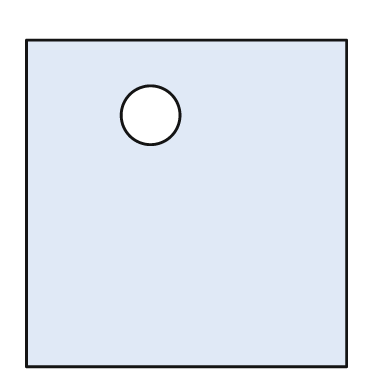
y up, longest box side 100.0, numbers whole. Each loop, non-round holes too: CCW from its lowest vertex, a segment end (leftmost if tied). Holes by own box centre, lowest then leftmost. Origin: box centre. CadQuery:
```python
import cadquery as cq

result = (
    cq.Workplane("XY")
    .moveTo(-49.0, -50.0)
    .lineTo(49.0, -50.0)
    .lineTo(49.0, 50.0)
    .lineTo(-49.0, 50.0)
    .close()
    .moveTo(-11.0, 27.0)
    .circle(9.0)
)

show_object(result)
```